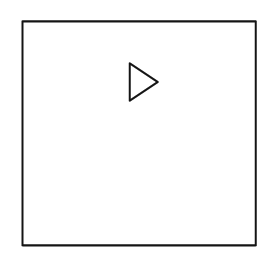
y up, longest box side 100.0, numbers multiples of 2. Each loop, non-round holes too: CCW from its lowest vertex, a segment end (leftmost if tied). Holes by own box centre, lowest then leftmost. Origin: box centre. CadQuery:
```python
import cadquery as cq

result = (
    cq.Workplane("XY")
    .moveTo(-50.0, -48.0)
    .lineTo(50.0, -48.0)
    .lineTo(50.0, 48.0)
    .lineTo(-50.0, 48.0)
    .close()
    .moveTo(-4.0, 14.0)
    .lineTo(8.0, 22.0)
    .lineTo(-4.0, 30.0)
    .close()
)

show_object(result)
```